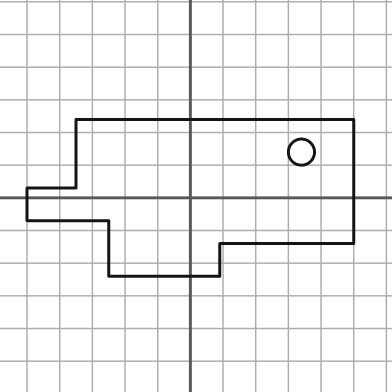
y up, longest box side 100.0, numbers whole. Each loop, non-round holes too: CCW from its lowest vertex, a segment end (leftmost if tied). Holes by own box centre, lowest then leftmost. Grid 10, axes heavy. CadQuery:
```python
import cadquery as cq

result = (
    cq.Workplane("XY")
    .moveTo(-25.0, -24.0)
    .lineTo(9.0, -24.0)
    .lineTo(9.0, -14.0)
    .lineTo(50.0, -14.0)
    .lineTo(50.0, 24.0)
    .lineTo(-35.0, 24.0)
    .lineTo(-35.0, 3.0)
    .lineTo(-50.0, 3.0)
    .lineTo(-50.0, -7.0)
    .lineTo(-25.0, -7.0)
    .close()
    .moveTo(34.0, 14.0)
    .circle(4.0)
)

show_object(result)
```